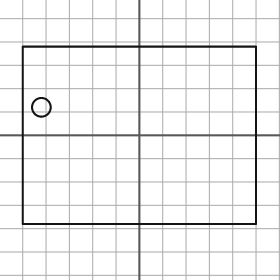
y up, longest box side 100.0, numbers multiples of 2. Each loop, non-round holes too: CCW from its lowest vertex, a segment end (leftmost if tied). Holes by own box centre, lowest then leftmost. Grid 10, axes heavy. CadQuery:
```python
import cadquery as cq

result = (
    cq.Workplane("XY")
    .moveTo(-50.0, -38.0)
    .lineTo(50.0, -38.0)
    .lineTo(50.0, 38.0)
    .lineTo(-50.0, 38.0)
    .close()
    .moveTo(-42.0, 12.0)
    .circle(4.0)
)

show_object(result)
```